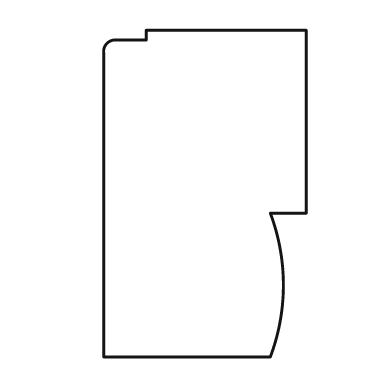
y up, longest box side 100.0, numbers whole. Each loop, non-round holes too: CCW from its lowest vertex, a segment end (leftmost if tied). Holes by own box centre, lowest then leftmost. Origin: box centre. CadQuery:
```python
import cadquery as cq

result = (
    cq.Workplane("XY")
    .moveTo(-31.0, -50.0)
    .lineTo(20.0, -50.0)
    .threePointArc((24.0, -28.0), (20.0, -6.0))
    .lineTo(31.0, -6.0)
    .lineTo(31.0, 50.0)
    .lineTo(-18.0, 50.0)
    .lineTo(-18.0, 47.0)
    .lineTo(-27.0, 47.0)
    .threePointArc((-30.0, 46.0), (-31.0, 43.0))
    .close()
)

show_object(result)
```